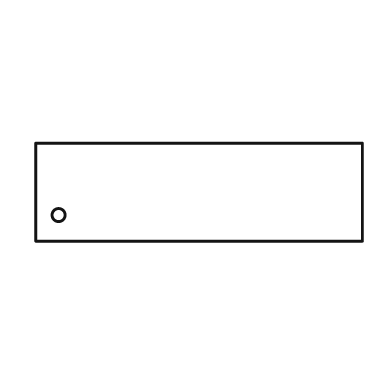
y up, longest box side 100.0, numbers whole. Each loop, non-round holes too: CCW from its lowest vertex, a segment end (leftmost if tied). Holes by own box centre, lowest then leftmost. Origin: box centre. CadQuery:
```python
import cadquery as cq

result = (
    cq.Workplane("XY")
    .moveTo(-50.0, -15.0)
    .lineTo(50.0, -15.0)
    .lineTo(50.0, 15.0)
    .lineTo(-50.0, 15.0)
    .close()
    .moveTo(-43.0, -7.0)
    .circle(2.0)
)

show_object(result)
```